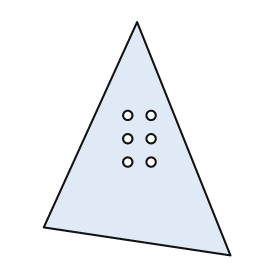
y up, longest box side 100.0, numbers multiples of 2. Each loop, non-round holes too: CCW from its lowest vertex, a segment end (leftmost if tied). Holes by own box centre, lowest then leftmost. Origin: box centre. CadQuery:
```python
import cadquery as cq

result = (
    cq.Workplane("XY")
    .moveTo(40.0, -50.0)
    .lineTo(0.0, 50.0)
    .lineTo(-40.0, -38.0)
    .close()
    .moveTo(-4.0, -10.0)
    .circle(2.0)
    .moveTo(6.0, -10.0)
    .circle(2.0)
    .moveTo(-4.0, 0.0)
    .circle(2.0)
    .moveTo(6.0, 0.0)
    .circle(2.0)
    .moveTo(-4.0, 10.0)
    .circle(2.0)
    .moveTo(6.0, 10.0)
    .circle(2.0)
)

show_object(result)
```